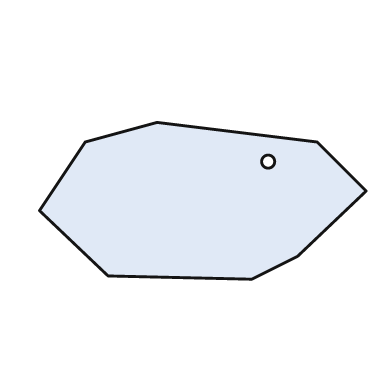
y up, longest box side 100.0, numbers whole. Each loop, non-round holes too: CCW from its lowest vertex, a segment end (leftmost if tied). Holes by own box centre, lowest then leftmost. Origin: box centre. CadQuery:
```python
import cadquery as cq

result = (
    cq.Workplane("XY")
    .moveTo(15.0, -24.0)
    .lineTo(29.0, -17.0)
    .lineTo(50.0, 3.0)
    .lineTo(35.0, 18.0)
    .lineTo(-14.0, 24.0)
    .lineTo(-36.0, 18.0)
    .lineTo(-50.0, -3.0)
    .lineTo(-29.0, -23.0)
    .close()
    .moveTo(20.0, 12.0)
    .circle(2.0)
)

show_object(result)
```